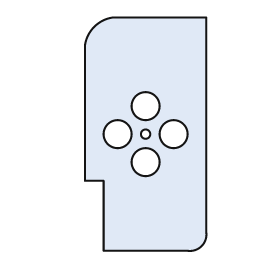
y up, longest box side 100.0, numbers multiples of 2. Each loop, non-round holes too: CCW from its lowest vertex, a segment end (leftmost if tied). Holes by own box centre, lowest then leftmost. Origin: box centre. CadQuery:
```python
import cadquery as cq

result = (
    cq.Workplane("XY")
    .moveTo(-18.0, -50.0)
    .lineTo(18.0, -50.0)
    .threePointArc((24.0, -48.0), (26.0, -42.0))
    .lineTo(26.0, 50.0)
    .lineTo(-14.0, 50.0)
    .threePointArc((-22.0, 46.0), (-26.0, 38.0))
    .lineTo(-26.0, -20.0)
    .lineTo(-18.0, -20.0)
    .close()
    .moveTo(0.0, -12.0)
    .circle(6.0)
    .moveTo(-12.0, 0.0)
    .circle(6.0)
    .moveTo(0.0, 0.0)
    .circle(2.0)
    .moveTo(12.0, 0.0)
    .circle(6.0)
    .moveTo(0.0, 12.0)
    .circle(6.0)
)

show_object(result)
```